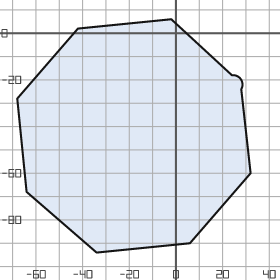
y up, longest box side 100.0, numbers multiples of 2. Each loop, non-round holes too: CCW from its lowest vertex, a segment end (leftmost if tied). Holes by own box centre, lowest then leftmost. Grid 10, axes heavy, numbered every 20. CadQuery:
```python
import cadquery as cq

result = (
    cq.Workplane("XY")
    .moveTo(-34.0, -94.0)
    .lineTo(6.0, -90.0)
    .lineTo(32.0, -60.0)
    .lineTo(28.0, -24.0)
    .threePointArc((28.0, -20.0), (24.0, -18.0))
    .lineTo(-2.0, 6.0)
    .lineTo(-42.0, 2.0)
    .lineTo(-68.0, -28.0)
    .lineTo(-64.0, -68.0)
    .close()
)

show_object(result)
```